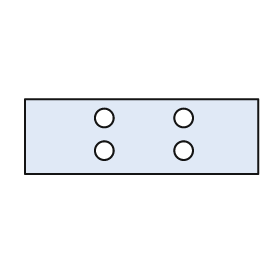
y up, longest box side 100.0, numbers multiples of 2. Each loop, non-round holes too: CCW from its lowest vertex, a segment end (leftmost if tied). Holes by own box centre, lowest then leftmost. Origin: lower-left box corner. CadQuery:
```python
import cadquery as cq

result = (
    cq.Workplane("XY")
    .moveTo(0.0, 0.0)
    .lineTo(100.0, 0.0)
    .lineTo(100.0, 32.0)
    .lineTo(0.0, 32.0)
    .close()
    .moveTo(34.0, 10.0)
    .circle(4.0)
    .moveTo(68.0, 10.0)
    .circle(4.0)
    .moveTo(34.0, 24.0)
    .circle(4.0)
    .moveTo(68.0, 24.0)
    .circle(4.0)
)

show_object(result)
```